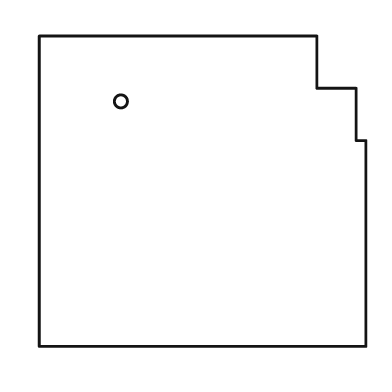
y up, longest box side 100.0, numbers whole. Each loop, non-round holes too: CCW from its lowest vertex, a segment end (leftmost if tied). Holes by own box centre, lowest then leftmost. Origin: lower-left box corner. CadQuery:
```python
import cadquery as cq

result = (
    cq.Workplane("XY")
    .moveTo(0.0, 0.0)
    .lineTo(100.0, 0.0)
    .lineTo(100.0, 63.0)
    .lineTo(97.0, 63.0)
    .lineTo(97.0, 79.0)
    .lineTo(85.0, 79.0)
    .lineTo(85.0, 95.0)
    .lineTo(0.0, 95.0)
    .close()
    .moveTo(25.0, 75.0)
    .circle(2.0)
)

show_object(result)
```